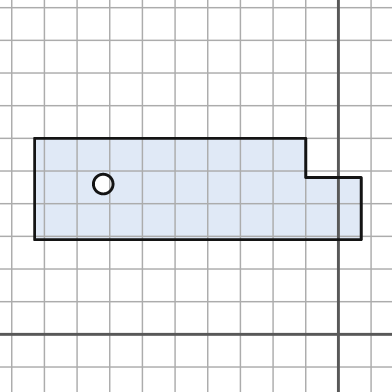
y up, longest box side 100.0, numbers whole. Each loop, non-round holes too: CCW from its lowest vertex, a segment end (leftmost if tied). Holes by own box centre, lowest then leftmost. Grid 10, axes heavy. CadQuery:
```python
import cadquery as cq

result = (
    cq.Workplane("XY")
    .moveTo(-93.0, 29.0)
    .lineTo(7.0, 29.0)
    .lineTo(7.0, 48.0)
    .lineTo(-10.0, 48.0)
    .lineTo(-10.0, 60.0)
    .lineTo(-93.0, 60.0)
    .close()
    .moveTo(-72.0, 46.0)
    .circle(3.0)
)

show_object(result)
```